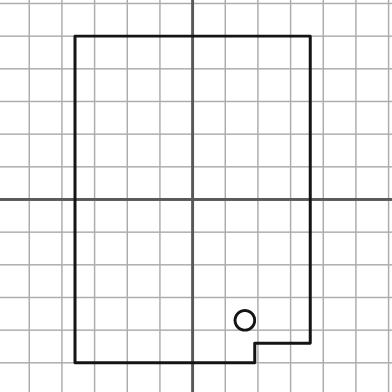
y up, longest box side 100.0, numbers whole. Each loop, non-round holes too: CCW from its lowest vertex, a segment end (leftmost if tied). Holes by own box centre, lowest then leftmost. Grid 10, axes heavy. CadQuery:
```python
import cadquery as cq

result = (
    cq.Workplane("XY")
    .moveTo(-36.0, -50.0)
    .lineTo(19.0, -50.0)
    .lineTo(19.0, -44.0)
    .lineTo(36.0, -44.0)
    .lineTo(36.0, 50.0)
    .lineTo(-36.0, 50.0)
    .close()
    .moveTo(16.0, -37.0)
    .circle(3.0)
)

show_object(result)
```